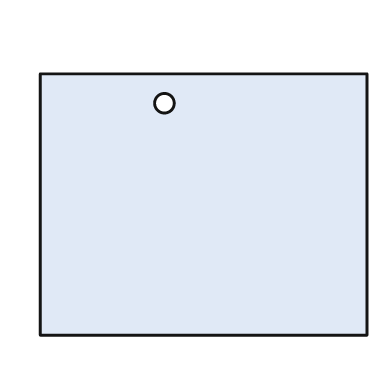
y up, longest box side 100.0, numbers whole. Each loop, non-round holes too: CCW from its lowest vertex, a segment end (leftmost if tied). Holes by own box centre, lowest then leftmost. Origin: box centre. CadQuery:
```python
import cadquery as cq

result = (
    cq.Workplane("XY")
    .moveTo(-50.0, -40.0)
    .lineTo(50.0, -40.0)
    .lineTo(50.0, 40.0)
    .lineTo(-50.0, 40.0)
    .close()
    .moveTo(-12.0, 31.0)
    .circle(3.0)
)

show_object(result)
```